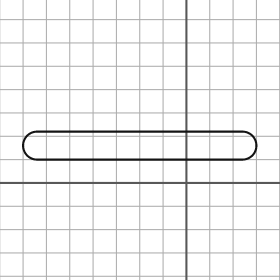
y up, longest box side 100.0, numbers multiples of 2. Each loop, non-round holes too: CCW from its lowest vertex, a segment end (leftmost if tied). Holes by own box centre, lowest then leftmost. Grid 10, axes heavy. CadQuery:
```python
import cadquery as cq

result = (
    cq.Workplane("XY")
    .moveTo(-64.0, 10.0)
    .lineTo(24.0, 10.0)
    .threePointArc((30.0, 16.0), (24.0, 22.0))
    .lineTo(-64.0, 22.0)
    .threePointArc((-70.0, 16.0), (-64.0, 10.0))
    .close()
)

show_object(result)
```